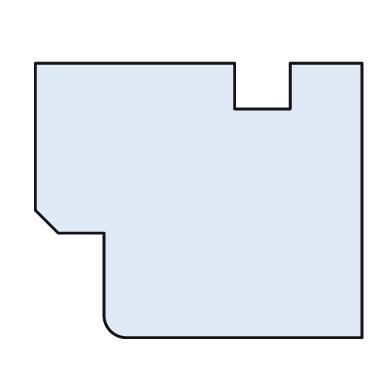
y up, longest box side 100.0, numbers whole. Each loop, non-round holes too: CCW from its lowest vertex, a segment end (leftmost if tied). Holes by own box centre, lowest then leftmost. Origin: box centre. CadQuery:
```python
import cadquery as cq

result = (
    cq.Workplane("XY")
    .moveTo(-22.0, -42.0)
    .lineTo(50.0, -42.0)
    .lineTo(50.0, 42.0)
    .lineTo(28.0, 42.0)
    .lineTo(28.0, 28.0)
    .lineTo(11.0, 28.0)
    .lineTo(11.0, 42.0)
    .lineTo(-50.0, 42.0)
    .lineTo(-50.0, -3.0)
    .lineTo(-43.0, -10.0)
    .lineTo(-29.0, -10.0)
    .lineTo(-29.0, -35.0)
    .threePointArc((-27.0, -40.0), (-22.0, -42.0))
    .close()
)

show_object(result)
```